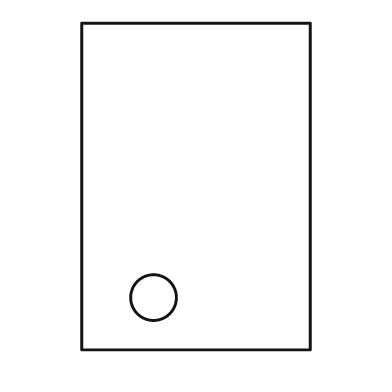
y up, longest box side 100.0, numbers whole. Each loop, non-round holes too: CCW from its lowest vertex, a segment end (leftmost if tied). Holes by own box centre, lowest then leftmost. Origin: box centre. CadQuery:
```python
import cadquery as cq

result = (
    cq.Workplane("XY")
    .moveTo(-35.0, -50.0)
    .lineTo(35.0, -50.0)
    .lineTo(35.0, 50.0)
    .lineTo(-35.0, 50.0)
    .close()
    .moveTo(-13.0, -34.0)
    .circle(7.0)
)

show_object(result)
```